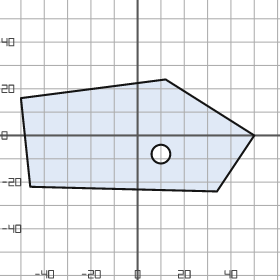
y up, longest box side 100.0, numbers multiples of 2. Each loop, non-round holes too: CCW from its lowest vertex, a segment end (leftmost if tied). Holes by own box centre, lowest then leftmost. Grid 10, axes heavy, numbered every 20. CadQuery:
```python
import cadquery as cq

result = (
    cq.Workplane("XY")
    .moveTo(34.0, -24.0)
    .lineTo(50.0, 0.0)
    .lineTo(12.0, 24.0)
    .lineTo(-50.0, 16.0)
    .lineTo(-46.0, -22.0)
    .close()
    .moveTo(10.0, -8.0)
    .circle(4.0)
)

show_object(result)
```